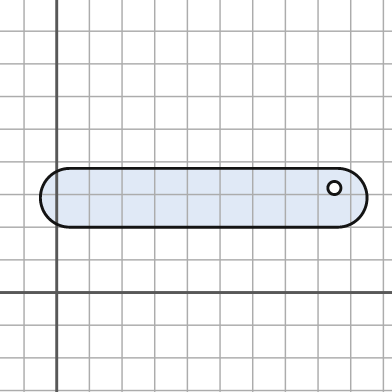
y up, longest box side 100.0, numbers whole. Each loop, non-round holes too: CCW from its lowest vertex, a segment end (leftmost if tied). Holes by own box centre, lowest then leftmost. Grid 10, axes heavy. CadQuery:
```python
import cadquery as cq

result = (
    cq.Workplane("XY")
    .moveTo(4.0, 20.0)
    .lineTo(86.0, 20.0)
    .threePointArc((95.0, 29.0), (86.0, 38.0))
    .lineTo(4.0, 38.0)
    .threePointArc((-5.0, 29.0), (4.0, 20.0))
    .close()
    .moveTo(85.0, 32.0)
    .circle(2.0)
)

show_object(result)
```